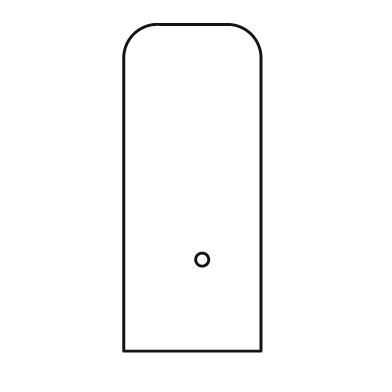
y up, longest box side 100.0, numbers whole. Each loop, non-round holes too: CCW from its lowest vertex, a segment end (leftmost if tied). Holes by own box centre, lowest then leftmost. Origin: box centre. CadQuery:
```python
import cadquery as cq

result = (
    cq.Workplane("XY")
    .moveTo(-21.0, -50.0)
    .lineTo(21.0, -50.0)
    .lineTo(21.0, 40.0)
    .threePointArc((18.0, 47.0), (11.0, 50.0))
    .lineTo(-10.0, 50.0)
    .threePointArc((-18.0, 47.0), (-21.0, 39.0))
    .close()
    .moveTo(3.0, -22.0)
    .circle(2.0)
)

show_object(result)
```